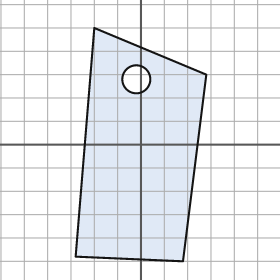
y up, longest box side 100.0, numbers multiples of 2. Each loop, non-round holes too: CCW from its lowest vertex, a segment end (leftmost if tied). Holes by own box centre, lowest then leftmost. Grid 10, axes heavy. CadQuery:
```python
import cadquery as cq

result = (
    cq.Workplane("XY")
    .moveTo(18.0, -50.0)
    .lineTo(28.0, 30.0)
    .lineTo(-20.0, 50.0)
    .lineTo(-28.0, -48.0)
    .close()
    .moveTo(-2.0, 28.0)
    .circle(6.0)
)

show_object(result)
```